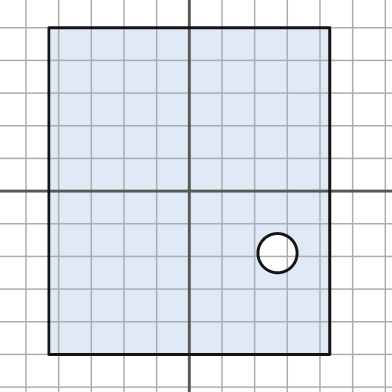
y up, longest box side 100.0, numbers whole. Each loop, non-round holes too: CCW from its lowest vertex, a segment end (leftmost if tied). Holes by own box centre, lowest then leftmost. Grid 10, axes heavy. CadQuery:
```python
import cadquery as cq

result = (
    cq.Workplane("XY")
    .moveTo(-43.0, -50.0)
    .lineTo(43.0, -50.0)
    .lineTo(43.0, 50.0)
    .lineTo(-43.0, 50.0)
    .close()
    .moveTo(27.0, -19.0)
    .circle(6.0)
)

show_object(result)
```